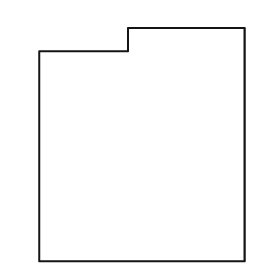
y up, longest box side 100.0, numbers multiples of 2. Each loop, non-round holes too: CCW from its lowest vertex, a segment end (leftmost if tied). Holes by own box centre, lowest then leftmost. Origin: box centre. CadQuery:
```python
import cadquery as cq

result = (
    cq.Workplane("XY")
    .moveTo(-44.0, -50.0)
    .lineTo(44.0, -50.0)
    .lineTo(44.0, 50.0)
    .lineTo(-6.0, 50.0)
    .lineTo(-6.0, 40.0)
    .lineTo(-44.0, 40.0)
    .close()
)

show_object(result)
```